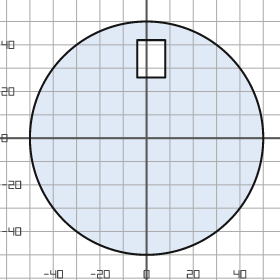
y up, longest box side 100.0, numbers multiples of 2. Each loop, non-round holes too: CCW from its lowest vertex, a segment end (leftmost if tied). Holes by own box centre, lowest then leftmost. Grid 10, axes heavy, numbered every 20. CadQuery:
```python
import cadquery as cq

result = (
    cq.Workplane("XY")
    .moveTo(0.0, 0.0)
    .circle(50.0)
    .moveTo(-4.0, 26.0)
    .lineTo(8.0, 26.0)
    .lineTo(8.0, 42.0)
    .lineTo(-4.0, 42.0)
    .close()
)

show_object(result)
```